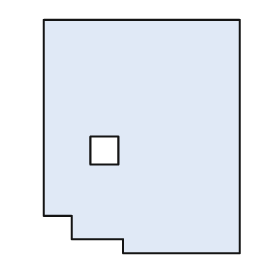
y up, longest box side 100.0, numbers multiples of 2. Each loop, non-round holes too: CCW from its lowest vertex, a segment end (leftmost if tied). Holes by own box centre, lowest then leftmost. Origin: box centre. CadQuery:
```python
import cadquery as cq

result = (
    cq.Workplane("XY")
    .moveTo(-8.0, -50.0)
    .lineTo(42.0, -50.0)
    .lineTo(42.0, 50.0)
    .lineTo(-42.0, 50.0)
    .lineTo(-42.0, -34.0)
    .lineTo(-30.0, -34.0)
    .lineTo(-30.0, -44.0)
    .lineTo(-8.0, -44.0)
    .close()
    .moveTo(-22.0, -12.0)
    .lineTo(-10.0, -12.0)
    .lineTo(-10.0, 0.0)
    .lineTo(-22.0, 0.0)
    .close()
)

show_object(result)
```